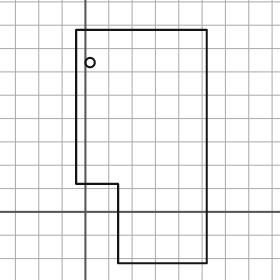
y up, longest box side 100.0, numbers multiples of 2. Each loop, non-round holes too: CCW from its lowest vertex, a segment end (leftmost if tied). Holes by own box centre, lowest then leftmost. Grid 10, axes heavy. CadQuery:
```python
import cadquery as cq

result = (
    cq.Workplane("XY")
    .moveTo(14.0, -22.0)
    .lineTo(52.0, -22.0)
    .lineTo(52.0, 78.0)
    .lineTo(-4.0, 78.0)
    .lineTo(-4.0, 12.0)
    .lineTo(14.0, 12.0)
    .close()
    .moveTo(2.0, 64.0)
    .circle(2.0)
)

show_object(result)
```